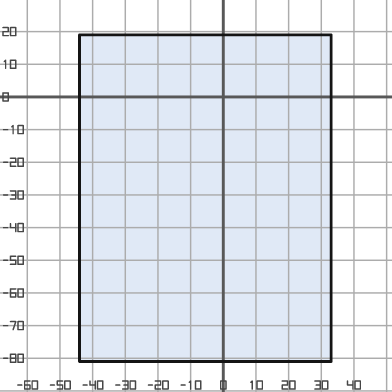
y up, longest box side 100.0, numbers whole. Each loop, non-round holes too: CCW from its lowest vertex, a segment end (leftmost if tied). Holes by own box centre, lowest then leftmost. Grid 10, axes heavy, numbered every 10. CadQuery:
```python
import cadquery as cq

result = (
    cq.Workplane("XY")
    .moveTo(-44.0, -81.0)
    .lineTo(33.0, -81.0)
    .lineTo(33.0, 19.0)
    .lineTo(-44.0, 19.0)
    .close()
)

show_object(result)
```